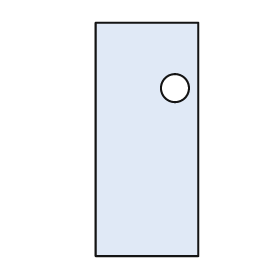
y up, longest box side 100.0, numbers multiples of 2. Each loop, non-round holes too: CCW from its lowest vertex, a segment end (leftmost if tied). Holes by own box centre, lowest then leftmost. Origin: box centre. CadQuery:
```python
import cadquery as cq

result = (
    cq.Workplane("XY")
    .moveTo(-22.0, -50.0)
    .lineTo(22.0, -50.0)
    .lineTo(22.0, 50.0)
    .lineTo(-22.0, 50.0)
    .close()
    .moveTo(12.0, 22.0)
    .circle(6.0)
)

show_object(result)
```